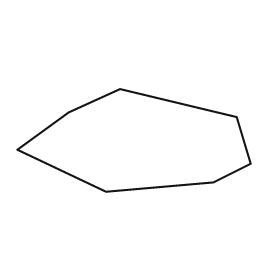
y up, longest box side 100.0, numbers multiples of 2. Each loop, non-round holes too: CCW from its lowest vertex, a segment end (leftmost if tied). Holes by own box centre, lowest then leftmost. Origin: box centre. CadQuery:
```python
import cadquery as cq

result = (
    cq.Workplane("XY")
    .moveTo(-12.0, -22.0)
    .lineTo(34.0, -18.0)
    .lineTo(50.0, -10.0)
    .lineTo(44.0, 10.0)
    .lineTo(-6.0, 22.0)
    .lineTo(-28.0, 12.0)
    .lineTo(-50.0, -4.0)
    .close()
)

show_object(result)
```